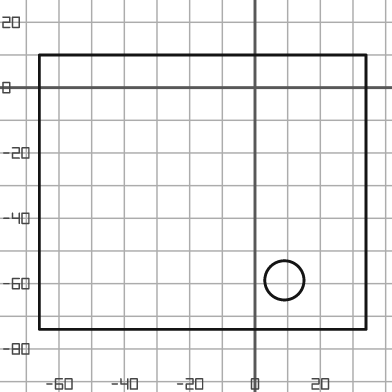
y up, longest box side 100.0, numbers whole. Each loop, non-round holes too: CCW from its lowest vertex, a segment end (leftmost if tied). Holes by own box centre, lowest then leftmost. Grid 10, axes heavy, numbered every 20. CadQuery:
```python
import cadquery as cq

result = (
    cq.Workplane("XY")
    .moveTo(-66.0, -74.0)
    .lineTo(34.0, -74.0)
    .lineTo(34.0, 10.0)
    .lineTo(-66.0, 10.0)
    .close()
    .moveTo(9.0, -59.0)
    .circle(6.0)
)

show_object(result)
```